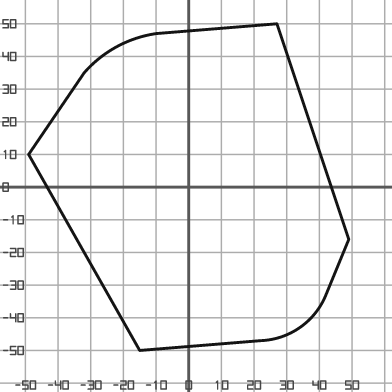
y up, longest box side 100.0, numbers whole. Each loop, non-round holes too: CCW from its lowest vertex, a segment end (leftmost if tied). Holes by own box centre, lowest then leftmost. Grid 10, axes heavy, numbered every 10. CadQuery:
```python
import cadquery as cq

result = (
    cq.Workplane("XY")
    .moveTo(-15.0, -50.0)
    .lineTo(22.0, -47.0)
    .threePointArc((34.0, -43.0), (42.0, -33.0))
    .lineTo(49.0, -16.0)
    .lineTo(27.0, 50.0)
    .lineTo(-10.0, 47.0)
    .threePointArc((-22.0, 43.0), (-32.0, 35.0))
    .lineTo(-49.0, 10.0)
    .close()
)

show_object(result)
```